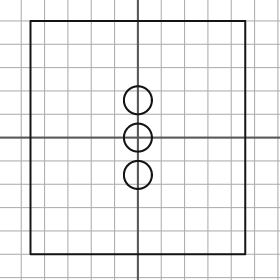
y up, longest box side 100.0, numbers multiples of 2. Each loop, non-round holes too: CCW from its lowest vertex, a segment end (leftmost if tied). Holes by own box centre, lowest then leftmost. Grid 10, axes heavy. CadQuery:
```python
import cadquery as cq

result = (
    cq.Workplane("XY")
    .moveTo(-46.0, -50.0)
    .lineTo(46.0, -50.0)
    .lineTo(46.0, 50.0)
    .lineTo(-46.0, 50.0)
    .close()
    .moveTo(0.0, -16.0)
    .circle(6.0)
    .moveTo(0.0, 0.0)
    .circle(6.0)
    .moveTo(0.0, 16.0)
    .circle(6.0)
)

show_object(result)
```